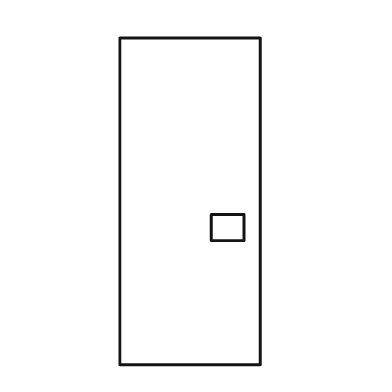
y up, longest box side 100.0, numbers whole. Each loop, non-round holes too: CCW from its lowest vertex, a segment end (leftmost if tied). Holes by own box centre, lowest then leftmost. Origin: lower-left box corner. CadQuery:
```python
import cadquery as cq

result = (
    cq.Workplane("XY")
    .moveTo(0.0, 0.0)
    .lineTo(43.0, 0.0)
    .lineTo(43.0, 100.0)
    .lineTo(0.0, 100.0)
    .close()
    .moveTo(28.0, 38.0)
    .lineTo(38.0, 38.0)
    .lineTo(38.0, 46.0)
    .lineTo(28.0, 46.0)
    .close()
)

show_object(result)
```